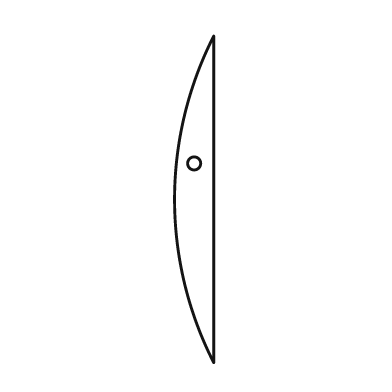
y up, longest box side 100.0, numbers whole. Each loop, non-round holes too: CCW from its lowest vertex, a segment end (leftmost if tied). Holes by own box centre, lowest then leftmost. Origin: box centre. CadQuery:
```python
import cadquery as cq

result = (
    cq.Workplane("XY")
    .moveTo(6.0, -50.0)
    .lineTo(6.0, 50.0)
    .threePointArc((-6.0, 0.0), (6.0, -50.0))
    .close()
    .moveTo(0.0, 11.0)
    .circle(2.0)
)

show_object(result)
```